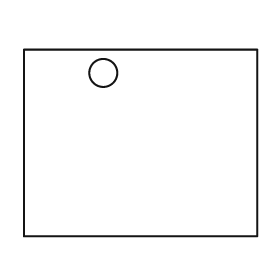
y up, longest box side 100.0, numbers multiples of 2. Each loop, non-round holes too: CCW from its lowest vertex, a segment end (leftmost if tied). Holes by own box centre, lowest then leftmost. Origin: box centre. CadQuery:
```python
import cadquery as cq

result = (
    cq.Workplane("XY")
    .moveTo(-50.0, -40.0)
    .lineTo(50.0, -40.0)
    .lineTo(50.0, 40.0)
    .lineTo(-50.0, 40.0)
    .close()
    .moveTo(-16.0, 30.0)
    .circle(6.0)
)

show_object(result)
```